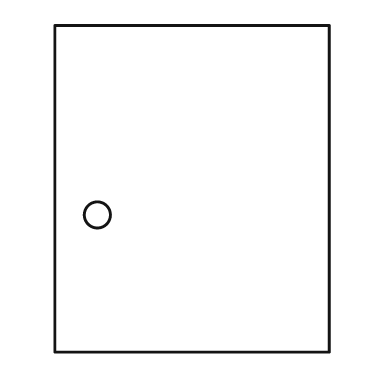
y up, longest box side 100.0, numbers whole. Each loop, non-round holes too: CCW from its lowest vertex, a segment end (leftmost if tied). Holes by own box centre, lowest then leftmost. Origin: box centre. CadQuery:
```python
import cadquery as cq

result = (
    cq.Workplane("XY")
    .moveTo(-42.0, -50.0)
    .lineTo(42.0, -50.0)
    .lineTo(42.0, 50.0)
    .lineTo(-42.0, 50.0)
    .close()
    .moveTo(-29.0, -8.0)
    .circle(4.0)
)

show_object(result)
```